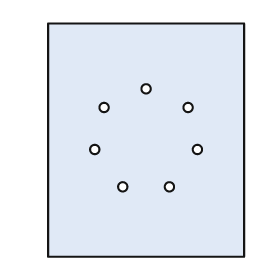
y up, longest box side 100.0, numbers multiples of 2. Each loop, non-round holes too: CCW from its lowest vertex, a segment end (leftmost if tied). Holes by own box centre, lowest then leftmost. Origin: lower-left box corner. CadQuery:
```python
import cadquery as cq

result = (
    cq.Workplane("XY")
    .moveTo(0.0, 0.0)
    .lineTo(84.0, 0.0)
    .lineTo(84.0, 100.0)
    .lineTo(0.0, 100.0)
    .close()
    .moveTo(32.0, 30.0)
    .circle(2.0)
    .moveTo(52.0, 30.0)
    .circle(2.0)
    .moveTo(20.0, 46.0)
    .circle(2.0)
    .moveTo(64.0, 46.0)
    .circle(2.0)
    .moveTo(24.0, 64.0)
    .circle(2.0)
    .moveTo(60.0, 64.0)
    .circle(2.0)
    .moveTo(42.0, 72.0)
    .circle(2.0)
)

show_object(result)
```